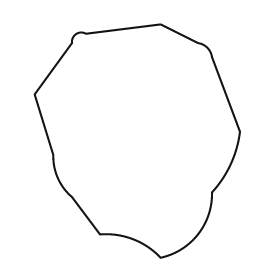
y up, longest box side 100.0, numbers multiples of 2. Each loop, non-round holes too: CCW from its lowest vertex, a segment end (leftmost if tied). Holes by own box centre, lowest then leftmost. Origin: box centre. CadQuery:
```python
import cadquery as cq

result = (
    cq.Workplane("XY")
    .moveTo(10.0, -50.0)
    .threePointArc((26.0, -40.0), (32.0, -22.0))
    .threePointArc((40.0, -10.0), (44.0, 4.0))
    .lineTo(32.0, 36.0)
    .threePointArc((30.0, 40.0), (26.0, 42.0))
    .lineTo(10.0, 50.0)
    .lineTo(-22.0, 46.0)
    .threePointArc((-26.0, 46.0), (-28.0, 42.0))
    .lineTo(-44.0, 20.0)
    .lineTo(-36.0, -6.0)
    .threePointArc((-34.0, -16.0), (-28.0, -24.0))
    .lineTo(-16.0, -40.0)
    .threePointArc((-2.0, -42.0), (10.0, -50.0))
    .close()
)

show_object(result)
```